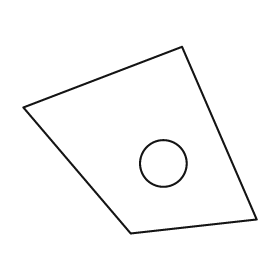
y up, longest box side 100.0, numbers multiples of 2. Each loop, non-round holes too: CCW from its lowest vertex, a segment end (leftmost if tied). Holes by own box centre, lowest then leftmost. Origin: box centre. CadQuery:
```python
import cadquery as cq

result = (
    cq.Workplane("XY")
    .moveTo(-4.0, -40.0)
    .lineTo(50.0, -34.0)
    .lineTo(18.0, 40.0)
    .lineTo(-50.0, 14.0)
    .close()
    .moveTo(10.0, -10.0)
    .circle(10.0)
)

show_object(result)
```